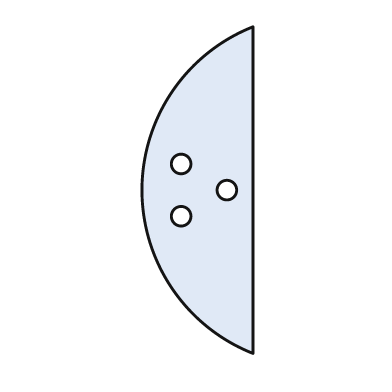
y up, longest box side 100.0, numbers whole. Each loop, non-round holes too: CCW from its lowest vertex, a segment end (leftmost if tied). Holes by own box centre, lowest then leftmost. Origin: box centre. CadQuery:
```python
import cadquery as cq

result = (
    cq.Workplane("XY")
    .moveTo(17.0, -50.0)
    .lineTo(17.0, 50.0)
    .threePointArc((-17.0, 0.0), (17.0, -50.0))
    .close()
    .moveTo(-5.0, -8.0)
    .circle(3.0)
    .moveTo(9.0, 0.0)
    .circle(3.0)
    .moveTo(-5.0, 8.0)
    .circle(3.0)
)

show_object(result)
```